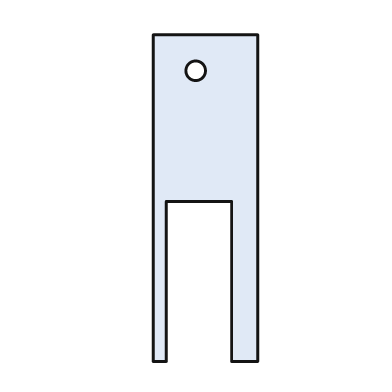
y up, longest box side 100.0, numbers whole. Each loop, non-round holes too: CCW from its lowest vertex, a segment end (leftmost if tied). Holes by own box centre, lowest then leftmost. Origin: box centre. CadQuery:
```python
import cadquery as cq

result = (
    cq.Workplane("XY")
    .moveTo(-16.0, -50.0)
    .lineTo(-12.0, -50.0)
    .lineTo(-12.0, -1.0)
    .lineTo(8.0, -1.0)
    .lineTo(8.0, -50.0)
    .lineTo(16.0, -50.0)
    .lineTo(16.0, 50.0)
    .lineTo(-16.0, 50.0)
    .close()
    .moveTo(-3.0, 39.0)
    .circle(3.0)
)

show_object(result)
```